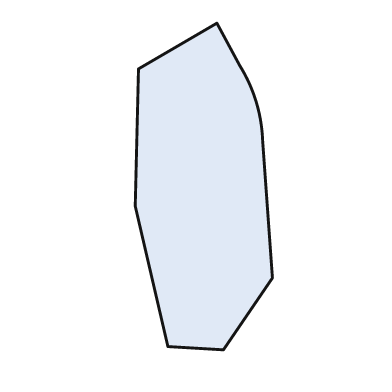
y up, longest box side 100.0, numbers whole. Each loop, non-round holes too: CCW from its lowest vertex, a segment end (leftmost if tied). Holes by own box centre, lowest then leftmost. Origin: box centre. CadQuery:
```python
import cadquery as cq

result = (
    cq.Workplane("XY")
    .moveTo(6.0, -50.0)
    .lineTo(21.0, -28.0)
    .lineTo(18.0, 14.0)
    .threePointArc((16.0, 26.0), (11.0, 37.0))
    .lineTo(4.0, 50.0)
    .lineTo(-20.0, 36.0)
    .lineTo(-21.0, -6.0)
    .lineTo(-11.0, -49.0)
    .close()
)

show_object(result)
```